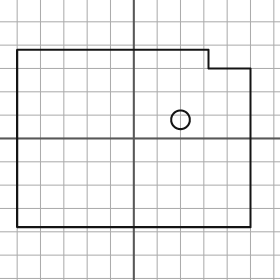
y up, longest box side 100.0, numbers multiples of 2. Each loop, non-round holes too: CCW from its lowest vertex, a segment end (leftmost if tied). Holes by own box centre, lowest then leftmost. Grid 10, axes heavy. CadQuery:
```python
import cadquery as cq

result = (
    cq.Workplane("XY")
    .moveTo(-50.0, -38.0)
    .lineTo(50.0, -38.0)
    .lineTo(50.0, 30.0)
    .lineTo(32.0, 30.0)
    .lineTo(32.0, 38.0)
    .lineTo(-50.0, 38.0)
    .close()
    .moveTo(20.0, 8.0)
    .circle(4.0)
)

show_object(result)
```